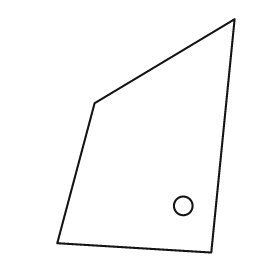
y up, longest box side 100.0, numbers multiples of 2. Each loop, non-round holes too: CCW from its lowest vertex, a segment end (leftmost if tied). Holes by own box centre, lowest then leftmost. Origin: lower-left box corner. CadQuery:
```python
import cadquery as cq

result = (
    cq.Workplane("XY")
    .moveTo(66.0, 0.0)
    .lineTo(76.0, 100.0)
    .lineTo(16.0, 64.0)
    .lineTo(0.0, 4.0)
    .close()
    .moveTo(54.0, 20.0)
    .circle(4.0)
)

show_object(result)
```